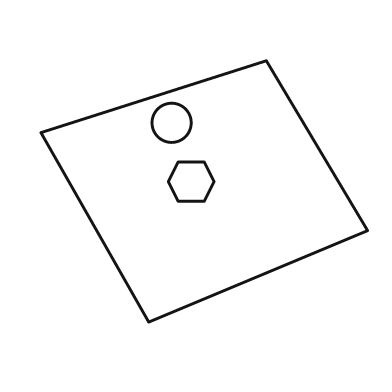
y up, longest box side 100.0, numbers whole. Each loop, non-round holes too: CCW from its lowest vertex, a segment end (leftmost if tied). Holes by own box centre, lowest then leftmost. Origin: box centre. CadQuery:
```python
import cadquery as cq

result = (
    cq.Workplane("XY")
    .moveTo(-17.0, -40.0)
    .lineTo(50.0, -12.0)
    .lineTo(19.0, 40.0)
    .lineTo(-50.0, 18.0)
    .close()
    .moveTo(-8.0, -3.0)
    .lineTo(0.0, -3.0)
    .lineTo(3.0, 3.0)
    .lineTo(0.0, 9.0)
    .lineTo(-8.0, 9.0)
    .lineTo(-11.0, 3.0)
    .close()
    .moveTo(-10.0, 21.0)
    .circle(6.0)
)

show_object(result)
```